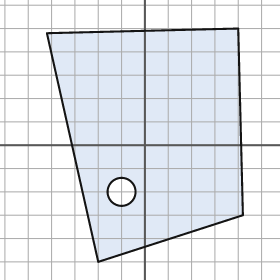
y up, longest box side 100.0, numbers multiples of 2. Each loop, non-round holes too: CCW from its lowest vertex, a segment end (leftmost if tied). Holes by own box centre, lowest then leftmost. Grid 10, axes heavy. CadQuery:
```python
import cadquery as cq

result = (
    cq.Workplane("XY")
    .moveTo(-20.0, -50.0)
    .lineTo(42.0, -30.0)
    .lineTo(40.0, 50.0)
    .lineTo(-42.0, 48.0)
    .close()
    .moveTo(-10.0, -20.0)
    .circle(6.0)
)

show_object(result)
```